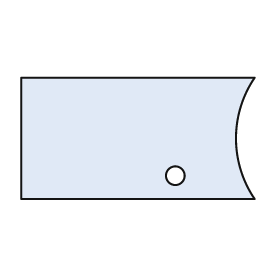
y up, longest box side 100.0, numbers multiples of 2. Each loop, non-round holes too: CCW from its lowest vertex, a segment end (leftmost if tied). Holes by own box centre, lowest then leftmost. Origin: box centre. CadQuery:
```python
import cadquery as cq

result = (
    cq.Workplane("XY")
    .moveTo(-50.0, -26.0)
    .lineTo(50.0, -26.0)
    .threePointArc((42.0, 0.0), (50.0, 26.0))
    .lineTo(-50.0, 26.0)
    .close()
    .moveTo(16.0, -16.0)
    .circle(4.0)
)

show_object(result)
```